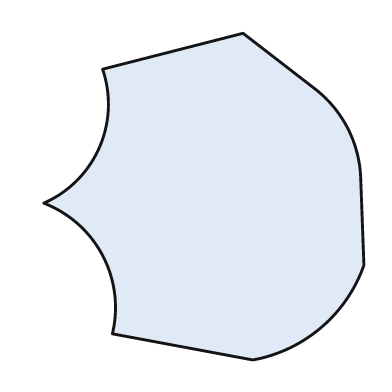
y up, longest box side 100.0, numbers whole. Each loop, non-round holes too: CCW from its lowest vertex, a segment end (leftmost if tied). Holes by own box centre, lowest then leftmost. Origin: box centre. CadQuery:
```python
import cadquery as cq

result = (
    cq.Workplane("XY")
    .moveTo(15.0, -50.0)
    .threePointArc((36.0, -40.0), (49.0, -21.0))
    .lineTo(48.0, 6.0)
    .threePointArc((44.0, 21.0), (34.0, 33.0))
    .lineTo(12.0, 50.0)
    .lineTo(-31.0, 39.0)
    .threePointArc((-32.0, 15.0), (-49.0, -2.0))
    .threePointArc((-31.0, -18.0), (-28.0, -42.0))
    .close()
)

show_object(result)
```